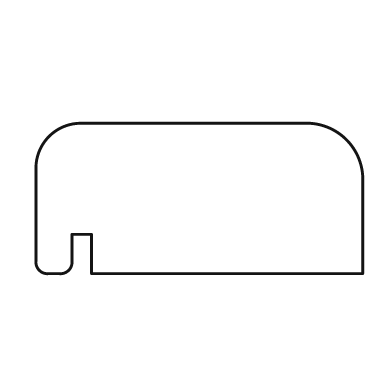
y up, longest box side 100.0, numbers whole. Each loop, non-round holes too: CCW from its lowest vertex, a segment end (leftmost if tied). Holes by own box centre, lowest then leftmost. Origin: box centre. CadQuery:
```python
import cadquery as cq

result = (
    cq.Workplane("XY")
    .moveTo(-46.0, -23.0)
    .lineTo(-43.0, -23.0)
    .threePointArc((-40.0, -22.0), (-39.0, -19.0))
    .lineTo(-39.0, -11.0)
    .lineTo(-33.0, -11.0)
    .lineTo(-33.0, -23.0)
    .lineTo(50.0, -23.0)
    .lineTo(50.0, 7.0)
    .threePointArc((45.0, 18.0), (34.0, 23.0))
    .lineTo(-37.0, 23.0)
    .threePointArc((-46.0, 19.0), (-50.0, 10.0))
    .lineTo(-50.0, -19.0)
    .threePointArc((-49.0, -22.0), (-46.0, -23.0))
    .close()
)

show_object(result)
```